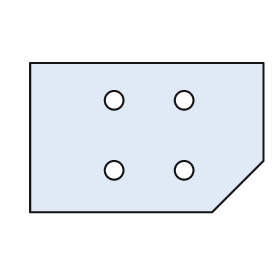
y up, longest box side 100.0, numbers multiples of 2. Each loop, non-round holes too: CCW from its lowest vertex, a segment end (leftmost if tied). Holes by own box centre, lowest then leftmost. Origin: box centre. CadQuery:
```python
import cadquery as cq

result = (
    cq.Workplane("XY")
    .moveTo(-50.0, -32.0)
    .lineTo(28.0, -32.0)
    .lineTo(50.0, -10.0)
    .lineTo(50.0, 32.0)
    .lineTo(-50.0, 32.0)
    .close()
    .moveTo(-14.0, -14.0)
    .circle(4.0)
    .moveTo(16.0, -14.0)
    .circle(4.0)
    .moveTo(-14.0, 16.0)
    .circle(4.0)
    .moveTo(16.0, 16.0)
    .circle(4.0)
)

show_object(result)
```